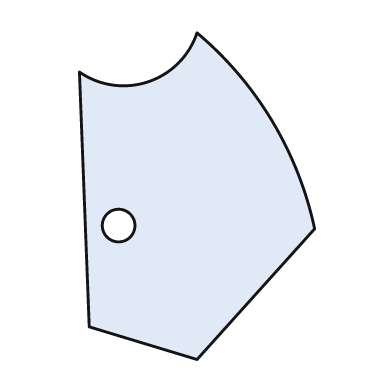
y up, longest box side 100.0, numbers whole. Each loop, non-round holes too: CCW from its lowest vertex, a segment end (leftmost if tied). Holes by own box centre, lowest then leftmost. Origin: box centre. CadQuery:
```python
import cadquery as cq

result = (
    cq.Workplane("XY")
    .moveTo(0.0, -50.0)
    .lineTo(36.0, -10.0)
    .threePointArc((23.0, 23.0), (0.0, 50.0))
    .threePointArc((-15.0, 35.0), (-36.0, 38.0))
    .lineTo(-33.0, -40.0)
    .close()
    .moveTo(-24.0, -9.0)
    .circle(5.0)
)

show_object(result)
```